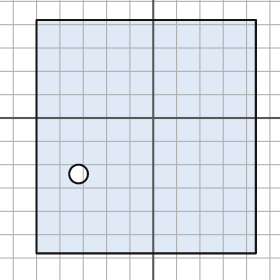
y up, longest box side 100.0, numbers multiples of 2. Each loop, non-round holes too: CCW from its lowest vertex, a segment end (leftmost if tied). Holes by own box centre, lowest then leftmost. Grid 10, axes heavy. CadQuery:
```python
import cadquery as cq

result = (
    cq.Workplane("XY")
    .moveTo(-50.0, -58.0)
    .lineTo(44.0, -58.0)
    .lineTo(44.0, 42.0)
    .lineTo(-50.0, 42.0)
    .close()
    .moveTo(-32.0, -24.0)
    .circle(4.0)
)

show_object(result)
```